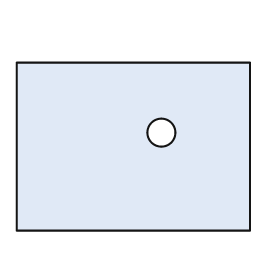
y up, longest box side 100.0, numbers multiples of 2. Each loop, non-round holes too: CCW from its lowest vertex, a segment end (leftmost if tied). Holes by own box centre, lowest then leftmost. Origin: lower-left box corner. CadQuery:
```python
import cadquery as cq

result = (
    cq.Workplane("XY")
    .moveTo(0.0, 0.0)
    .lineTo(100.0, 0.0)
    .lineTo(100.0, 72.0)
    .lineTo(0.0, 72.0)
    .close()
    .moveTo(62.0, 42.0)
    .circle(6.0)
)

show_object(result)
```